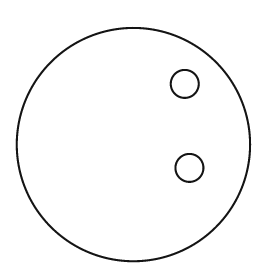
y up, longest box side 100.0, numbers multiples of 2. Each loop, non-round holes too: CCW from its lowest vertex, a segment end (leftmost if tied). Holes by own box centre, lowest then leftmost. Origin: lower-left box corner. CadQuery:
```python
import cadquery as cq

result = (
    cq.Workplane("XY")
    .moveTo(50.0, 50.0)
    .circle(50.0)
    .moveTo(74.0, 40.0)
    .circle(6.0)
    .moveTo(72.0, 76.0)
    .circle(6.0)
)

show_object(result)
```